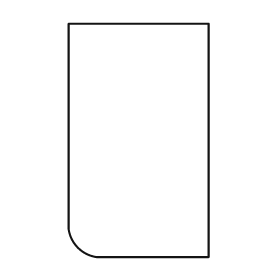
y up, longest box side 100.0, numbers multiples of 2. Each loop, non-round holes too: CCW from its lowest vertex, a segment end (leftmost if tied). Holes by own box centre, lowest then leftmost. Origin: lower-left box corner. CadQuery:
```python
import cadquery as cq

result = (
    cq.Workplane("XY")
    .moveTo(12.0, 0.0)
    .lineTo(60.0, 0.0)
    .lineTo(60.0, 100.0)
    .lineTo(0.0, 100.0)
    .lineTo(0.0, 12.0)
    .threePointArc((4.0, 4.0), (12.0, 0.0))
    .close()
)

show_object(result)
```